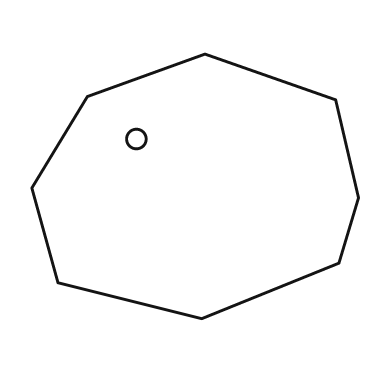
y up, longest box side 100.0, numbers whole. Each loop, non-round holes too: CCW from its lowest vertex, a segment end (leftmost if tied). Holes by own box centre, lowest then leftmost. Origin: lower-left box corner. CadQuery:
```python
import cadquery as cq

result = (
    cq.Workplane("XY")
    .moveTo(52.0, 0.0)
    .lineTo(94.0, 17.0)
    .lineTo(100.0, 37.0)
    .lineTo(93.0, 67.0)
    .lineTo(53.0, 81.0)
    .lineTo(17.0, 68.0)
    .lineTo(0.0, 40.0)
    .lineTo(8.0, 11.0)
    .close()
    .moveTo(32.0, 55.0)
    .circle(3.0)
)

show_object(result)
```